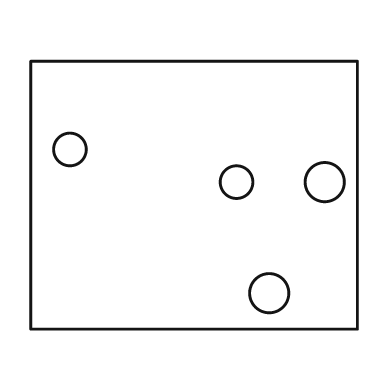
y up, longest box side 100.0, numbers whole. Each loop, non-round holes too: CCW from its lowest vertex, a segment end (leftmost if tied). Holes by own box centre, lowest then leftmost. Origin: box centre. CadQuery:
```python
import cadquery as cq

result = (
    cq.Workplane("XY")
    .moveTo(-50.0, -41.0)
    .lineTo(50.0, -41.0)
    .lineTo(50.0, 41.0)
    .lineTo(-50.0, 41.0)
    .close()
    .moveTo(23.0, -30.0)
    .circle(6.0)
    .moveTo(13.0, 4.0)
    .circle(5.0)
    .moveTo(40.0, 4.0)
    .circle(6.0)
    .moveTo(-38.0, 14.0)
    .circle(5.0)
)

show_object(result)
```